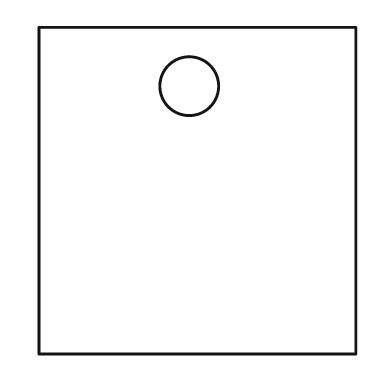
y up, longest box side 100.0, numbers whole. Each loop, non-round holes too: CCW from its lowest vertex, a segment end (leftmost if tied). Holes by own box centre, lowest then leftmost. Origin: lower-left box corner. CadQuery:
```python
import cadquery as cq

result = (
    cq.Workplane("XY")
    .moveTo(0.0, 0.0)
    .lineTo(97.0, 0.0)
    .lineTo(97.0, 100.0)
    .lineTo(0.0, 100.0)
    .close()
    .moveTo(46.0, 82.0)
    .circle(9.0)
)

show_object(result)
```